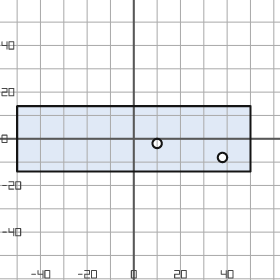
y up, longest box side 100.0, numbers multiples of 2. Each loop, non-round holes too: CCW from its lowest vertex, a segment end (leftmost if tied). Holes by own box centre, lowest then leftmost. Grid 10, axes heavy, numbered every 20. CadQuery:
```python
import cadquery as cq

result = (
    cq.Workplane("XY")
    .moveTo(-50.0, -14.0)
    .lineTo(50.0, -14.0)
    .lineTo(50.0, 14.0)
    .lineTo(-50.0, 14.0)
    .close()
    .moveTo(38.0, -8.0)
    .circle(2.0)
    .moveTo(10.0, -2.0)
    .circle(2.0)
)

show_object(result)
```